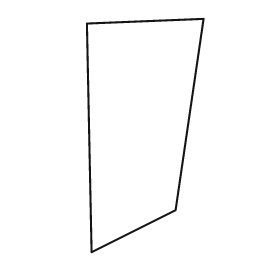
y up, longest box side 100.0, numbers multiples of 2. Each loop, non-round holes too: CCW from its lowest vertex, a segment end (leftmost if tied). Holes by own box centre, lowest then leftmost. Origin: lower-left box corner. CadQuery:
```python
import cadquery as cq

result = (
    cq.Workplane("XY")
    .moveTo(2.0, 0.0)
    .lineTo(38.0, 18.0)
    .lineTo(50.0, 100.0)
    .lineTo(0.0, 98.0)
    .close()
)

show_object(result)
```